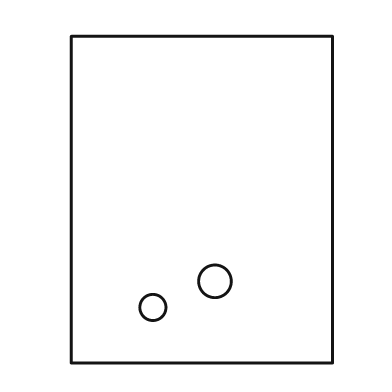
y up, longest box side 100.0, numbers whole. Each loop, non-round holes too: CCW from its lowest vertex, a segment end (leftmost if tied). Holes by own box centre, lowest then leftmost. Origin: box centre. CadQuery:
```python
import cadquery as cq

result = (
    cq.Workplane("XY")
    .moveTo(-40.0, -50.0)
    .lineTo(40.0, -50.0)
    .lineTo(40.0, 50.0)
    .lineTo(-40.0, 50.0)
    .close()
    .moveTo(-15.0, -33.0)
    .circle(4.0)
    .moveTo(4.0, -25.0)
    .circle(5.0)
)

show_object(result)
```